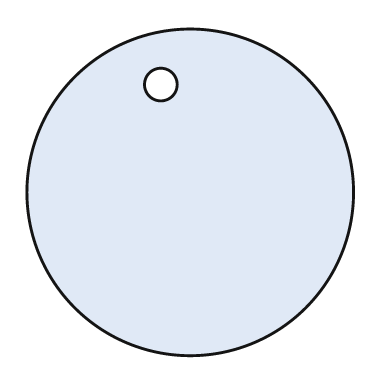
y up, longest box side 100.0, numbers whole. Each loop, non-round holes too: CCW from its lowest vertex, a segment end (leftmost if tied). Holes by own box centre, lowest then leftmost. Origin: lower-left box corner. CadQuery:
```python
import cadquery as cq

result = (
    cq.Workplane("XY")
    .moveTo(50.0, 50.0)
    .circle(50.0)
    .moveTo(41.0, 83.0)
    .circle(5.0)
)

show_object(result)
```